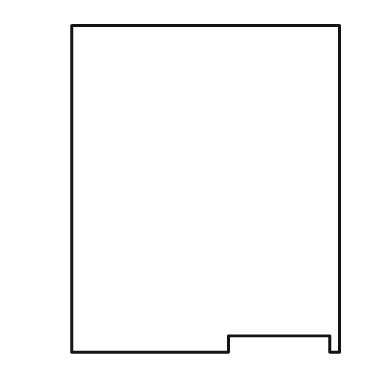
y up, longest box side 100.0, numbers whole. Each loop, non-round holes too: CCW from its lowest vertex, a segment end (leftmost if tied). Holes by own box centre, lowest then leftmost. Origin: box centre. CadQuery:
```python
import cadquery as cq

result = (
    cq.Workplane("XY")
    .moveTo(-41.0, -50.0)
    .lineTo(7.0, -50.0)
    .lineTo(7.0, -45.0)
    .lineTo(38.0, -45.0)
    .lineTo(38.0, -50.0)
    .lineTo(41.0, -50.0)
    .lineTo(41.0, 50.0)
    .lineTo(-41.0, 50.0)
    .close()
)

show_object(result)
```